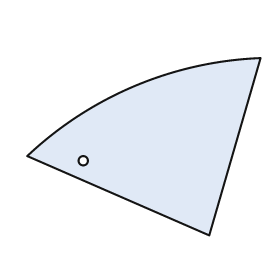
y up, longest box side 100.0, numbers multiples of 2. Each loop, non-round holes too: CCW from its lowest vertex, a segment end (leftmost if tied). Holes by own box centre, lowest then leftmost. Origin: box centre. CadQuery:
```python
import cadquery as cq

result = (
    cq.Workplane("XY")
    .moveTo(28.0, -38.0)
    .lineTo(50.0, 38.0)
    .threePointArc((-4.0, 26.0), (-50.0, -4.0))
    .close()
    .moveTo(-26.0, -6.0)
    .circle(2.0)
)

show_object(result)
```